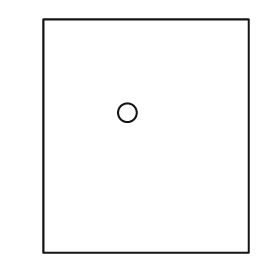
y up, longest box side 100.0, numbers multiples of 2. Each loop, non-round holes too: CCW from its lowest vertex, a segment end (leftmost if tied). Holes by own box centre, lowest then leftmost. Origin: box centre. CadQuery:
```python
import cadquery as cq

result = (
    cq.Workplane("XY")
    .moveTo(-44.0, -50.0)
    .lineTo(44.0, -50.0)
    .lineTo(44.0, 50.0)
    .lineTo(-44.0, 50.0)
    .close()
    .moveTo(-8.0, 10.0)
    .circle(4.0)
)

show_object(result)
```